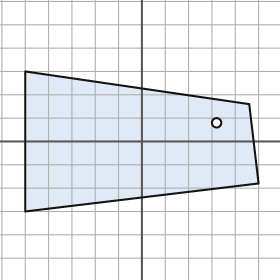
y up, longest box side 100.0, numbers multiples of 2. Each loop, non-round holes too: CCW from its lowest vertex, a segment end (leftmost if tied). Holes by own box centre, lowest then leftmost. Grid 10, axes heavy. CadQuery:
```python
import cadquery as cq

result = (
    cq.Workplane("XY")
    .moveTo(-50.0, -30.0)
    .lineTo(50.0, -18.0)
    .lineTo(46.0, 16.0)
    .lineTo(-50.0, 30.0)
    .close()
    .moveTo(32.0, 8.0)
    .circle(2.0)
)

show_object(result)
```